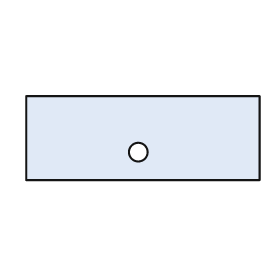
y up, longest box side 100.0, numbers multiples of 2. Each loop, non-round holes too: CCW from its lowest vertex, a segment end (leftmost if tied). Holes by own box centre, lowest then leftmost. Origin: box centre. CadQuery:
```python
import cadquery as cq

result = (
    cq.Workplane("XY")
    .moveTo(-50.0, -18.0)
    .lineTo(50.0, -18.0)
    .lineTo(50.0, 18.0)
    .lineTo(-50.0, 18.0)
    .close()
    .moveTo(-2.0, -6.0)
    .circle(4.0)
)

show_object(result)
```